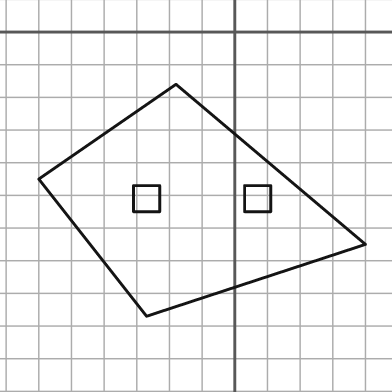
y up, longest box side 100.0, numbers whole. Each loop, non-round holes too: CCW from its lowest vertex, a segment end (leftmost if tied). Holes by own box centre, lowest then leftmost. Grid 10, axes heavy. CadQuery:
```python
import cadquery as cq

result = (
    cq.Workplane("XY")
    .moveTo(-27.0, -87.0)
    .lineTo(40.0, -65.0)
    .lineTo(-18.0, -16.0)
    .lineTo(-60.0, -45.0)
    .close()
    .moveTo(-31.0, -55.0)
    .lineTo(-23.0, -55.0)
    .lineTo(-23.0, -47.0)
    .lineTo(-31.0, -47.0)
    .close()
    .moveTo(3.0, -55.0)
    .lineTo(11.0, -55.0)
    .lineTo(11.0, -47.0)
    .lineTo(3.0, -47.0)
    .close()
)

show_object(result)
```